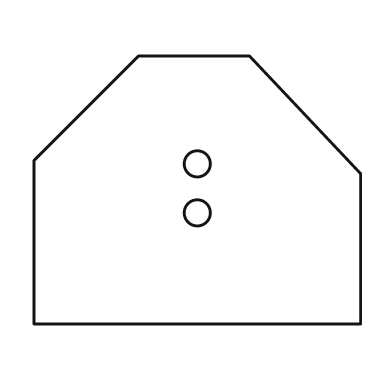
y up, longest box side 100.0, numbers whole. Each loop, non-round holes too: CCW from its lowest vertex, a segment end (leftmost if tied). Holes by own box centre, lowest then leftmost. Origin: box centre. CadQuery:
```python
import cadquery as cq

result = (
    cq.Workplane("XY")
    .moveTo(-50.0, -41.0)
    .lineTo(50.0, -41.0)
    .lineTo(50.0, 5.0)
    .lineTo(16.0, 41.0)
    .lineTo(-18.0, 41.0)
    .lineTo(-50.0, 9.0)
    .close()
    .moveTo(0.0, -7.0)
    .circle(4.0)
    .moveTo(0.0, 8.0)
    .circle(4.0)
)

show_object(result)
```